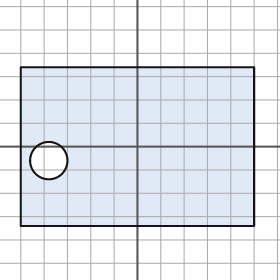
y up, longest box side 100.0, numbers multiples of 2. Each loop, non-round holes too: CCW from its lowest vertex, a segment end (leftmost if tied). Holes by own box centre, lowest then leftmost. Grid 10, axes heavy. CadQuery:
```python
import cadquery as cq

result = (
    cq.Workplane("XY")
    .moveTo(-50.0, -34.0)
    .lineTo(50.0, -34.0)
    .lineTo(50.0, 34.0)
    .lineTo(-50.0, 34.0)
    .close()
    .moveTo(-38.0, -6.0)
    .circle(8.0)
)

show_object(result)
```